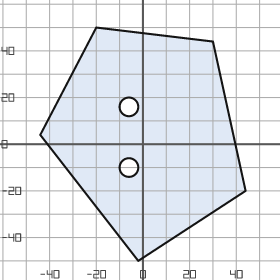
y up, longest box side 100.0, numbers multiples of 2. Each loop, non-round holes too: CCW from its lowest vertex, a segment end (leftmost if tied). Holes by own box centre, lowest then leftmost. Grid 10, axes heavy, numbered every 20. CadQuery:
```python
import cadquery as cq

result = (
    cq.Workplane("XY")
    .moveTo(-2.0, -50.0)
    .lineTo(44.0, -20.0)
    .lineTo(30.0, 44.0)
    .lineTo(-20.0, 50.0)
    .lineTo(-44.0, 4.0)
    .close()
    .moveTo(-6.0, -10.0)
    .circle(4.0)
    .moveTo(-6.0, 16.0)
    .circle(4.0)
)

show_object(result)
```